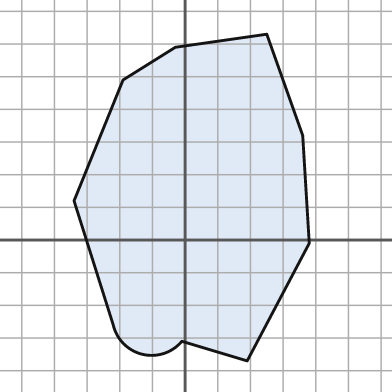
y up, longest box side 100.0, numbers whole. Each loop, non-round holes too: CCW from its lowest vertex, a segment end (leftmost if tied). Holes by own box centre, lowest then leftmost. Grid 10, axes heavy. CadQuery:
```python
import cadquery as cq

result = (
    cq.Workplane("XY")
    .moveTo(19.0, -37.0)
    .lineTo(38.0, -1.0)
    .lineTo(36.0, 32.0)
    .lineTo(25.0, 63.0)
    .lineTo(-3.0, 59.0)
    .lineTo(-19.0, 49.0)
    .lineTo(-34.0, 12.0)
    .lineTo(-22.0, -26.0)
    .threePointArc((-13.0, -35.0), (-1.0, -31.0))
    .close()
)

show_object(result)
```